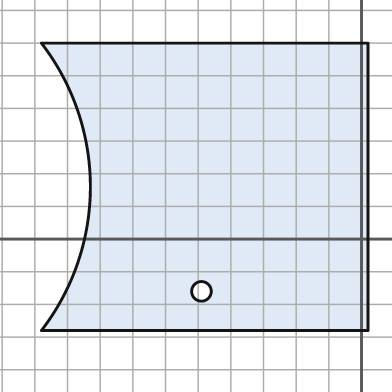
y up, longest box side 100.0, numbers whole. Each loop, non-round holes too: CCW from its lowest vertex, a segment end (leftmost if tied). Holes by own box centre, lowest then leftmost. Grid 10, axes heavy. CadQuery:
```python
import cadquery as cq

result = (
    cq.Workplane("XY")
    .moveTo(-98.0, -28.0)
    .lineTo(2.0, -28.0)
    .lineTo(2.0, 60.0)
    .lineTo(-98.0, 60.0)
    .threePointArc((-83.0, 16.0), (-98.0, -28.0))
    .close()
    .moveTo(-49.0, -16.0)
    .circle(3.0)
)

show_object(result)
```